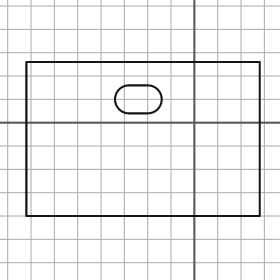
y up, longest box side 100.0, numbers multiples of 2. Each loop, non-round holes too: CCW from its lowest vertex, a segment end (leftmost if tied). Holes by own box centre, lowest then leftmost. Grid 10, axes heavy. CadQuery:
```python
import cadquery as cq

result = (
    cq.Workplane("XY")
    .moveTo(-72.0, -40.0)
    .lineTo(28.0, -40.0)
    .lineTo(28.0, 26.0)
    .lineTo(-72.0, 26.0)
    .close()
    .moveTo(-28.0, 4.0)
    .lineTo(-20.0, 4.0)
    .threePointArc((-14.0, 10.0), (-20.0, 16.0))
    .lineTo(-28.0, 16.0)
    .threePointArc((-34.0, 10.0), (-28.0, 4.0))
    .close()
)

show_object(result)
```